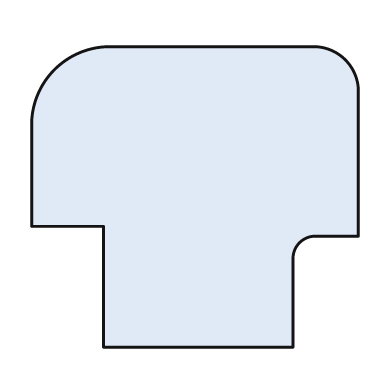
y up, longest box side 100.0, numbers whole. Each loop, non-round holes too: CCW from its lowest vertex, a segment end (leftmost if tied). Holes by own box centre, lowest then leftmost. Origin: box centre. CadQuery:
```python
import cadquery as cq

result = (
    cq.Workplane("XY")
    .moveTo(-28.0, -46.0)
    .lineTo(30.0, -46.0)
    .lineTo(30.0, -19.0)
    .threePointArc((32.0, -14.0), (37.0, -12.0))
    .lineTo(50.0, -12.0)
    .lineTo(50.0, 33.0)
    .threePointArc((46.0, 42.0), (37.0, 46.0))
    .lineTo(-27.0, 46.0)
    .threePointArc((-43.0, 39.0), (-50.0, 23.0))
    .lineTo(-50.0, -9.0)
    .lineTo(-28.0, -9.0)
    .close()
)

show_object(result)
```